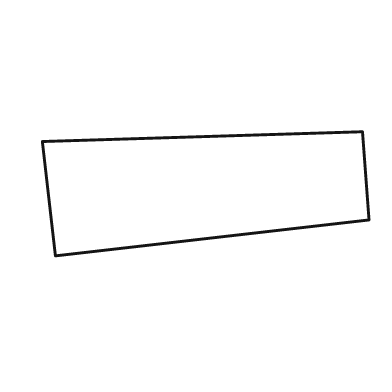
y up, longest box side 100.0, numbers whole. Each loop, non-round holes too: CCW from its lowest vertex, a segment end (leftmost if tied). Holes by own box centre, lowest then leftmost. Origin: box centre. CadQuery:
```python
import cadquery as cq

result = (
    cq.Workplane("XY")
    .moveTo(-46.0, -19.0)
    .lineTo(50.0, -8.0)
    .lineTo(48.0, 19.0)
    .lineTo(-50.0, 16.0)
    .close()
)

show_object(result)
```